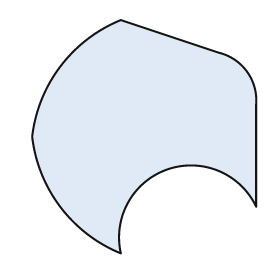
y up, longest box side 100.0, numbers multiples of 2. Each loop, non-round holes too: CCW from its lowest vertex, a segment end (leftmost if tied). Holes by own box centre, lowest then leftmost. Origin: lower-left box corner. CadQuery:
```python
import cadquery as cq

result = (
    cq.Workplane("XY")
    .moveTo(38.0, 0.0)
    .threePointArc((58.0, 36.0), (96.0, 20.0))
    .lineTo(96.0, 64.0)
    .threePointArc((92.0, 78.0), (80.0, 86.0))
    .lineTo(38.0, 100.0)
    .threePointArc((12.0, 80.0), (0.0, 50.0))
    .threePointArc((12.0, 20.0), (38.0, 0.0))
    .close()
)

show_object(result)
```